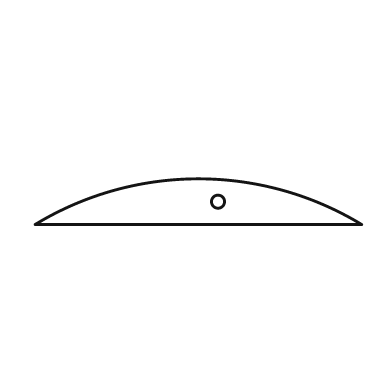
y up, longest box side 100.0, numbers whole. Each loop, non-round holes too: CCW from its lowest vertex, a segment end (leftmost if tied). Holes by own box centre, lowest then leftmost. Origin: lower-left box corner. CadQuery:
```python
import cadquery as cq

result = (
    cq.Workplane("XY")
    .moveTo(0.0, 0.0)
    .lineTo(100.0, 0.0)
    .threePointArc((50.0, 14.0), (0.0, 0.0))
    .close()
    .moveTo(56.0, 7.0)
    .circle(2.0)
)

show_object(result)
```